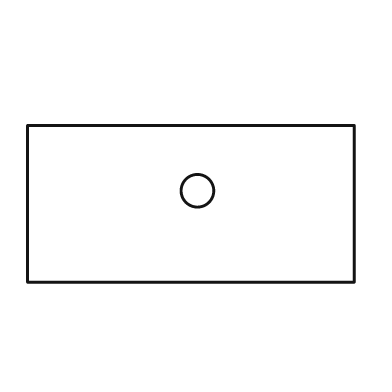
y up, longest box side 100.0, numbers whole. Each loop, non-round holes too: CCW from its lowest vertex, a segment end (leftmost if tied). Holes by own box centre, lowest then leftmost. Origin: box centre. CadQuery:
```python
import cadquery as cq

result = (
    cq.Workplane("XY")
    .moveTo(-50.0, -24.0)
    .lineTo(50.0, -24.0)
    .lineTo(50.0, 24.0)
    .lineTo(-50.0, 24.0)
    .close()
    .moveTo(2.0, 4.0)
    .circle(5.0)
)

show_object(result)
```